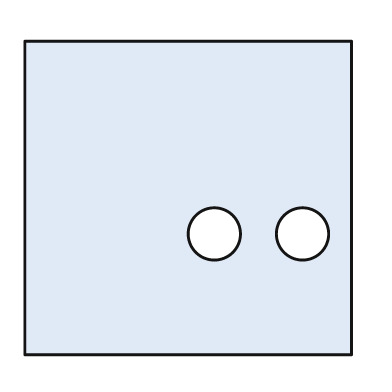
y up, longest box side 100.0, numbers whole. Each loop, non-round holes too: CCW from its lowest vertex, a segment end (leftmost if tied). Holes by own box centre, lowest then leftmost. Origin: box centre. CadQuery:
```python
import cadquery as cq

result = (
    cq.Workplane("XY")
    .moveTo(-50.0, -48.0)
    .lineTo(50.0, -48.0)
    .lineTo(50.0, 48.0)
    .lineTo(-50.0, 48.0)
    .close()
    .moveTo(8.0, -11.0)
    .circle(8.0)
    .moveTo(35.0, -11.0)
    .circle(8.0)
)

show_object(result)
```